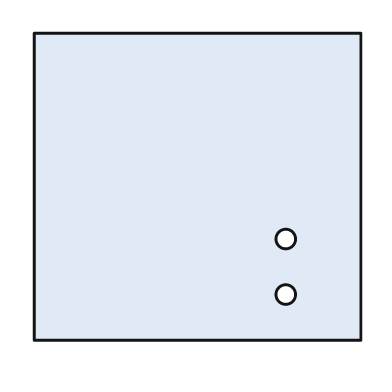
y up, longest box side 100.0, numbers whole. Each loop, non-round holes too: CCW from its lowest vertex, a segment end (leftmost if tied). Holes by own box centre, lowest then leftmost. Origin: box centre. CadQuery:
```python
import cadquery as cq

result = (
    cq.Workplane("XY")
    .moveTo(-50.0, -47.0)
    .lineTo(50.0, -47.0)
    .lineTo(50.0, 47.0)
    .lineTo(-50.0, 47.0)
    .close()
    .moveTo(27.0, -33.0)
    .circle(3.0)
    .moveTo(27.0, -16.0)
    .circle(3.0)
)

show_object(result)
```